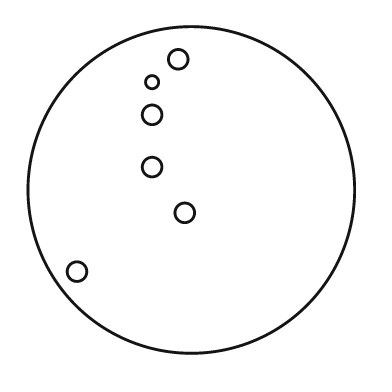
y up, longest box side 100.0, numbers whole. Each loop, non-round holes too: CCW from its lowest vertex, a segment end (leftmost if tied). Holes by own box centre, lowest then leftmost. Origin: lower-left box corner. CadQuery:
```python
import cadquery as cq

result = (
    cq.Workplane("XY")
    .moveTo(50.0, 50.0)
    .circle(50.0)
    .moveTo(15.0, 25.0)
    .circle(3.0)
    .moveTo(48.0, 43.0)
    .circle(3.0)
    .moveTo(38.0, 57.0)
    .circle(3.0)
    .moveTo(38.0, 73.0)
    .circle(3.0)
    .moveTo(38.0, 83.0)
    .circle(2.0)
    .moveTo(46.0, 90.0)
    .circle(3.0)
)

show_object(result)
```